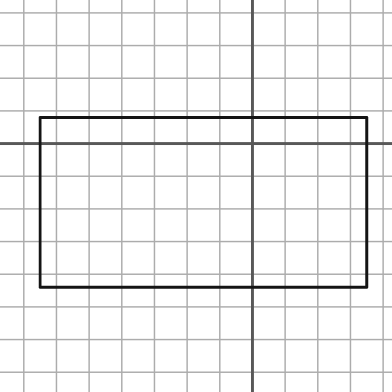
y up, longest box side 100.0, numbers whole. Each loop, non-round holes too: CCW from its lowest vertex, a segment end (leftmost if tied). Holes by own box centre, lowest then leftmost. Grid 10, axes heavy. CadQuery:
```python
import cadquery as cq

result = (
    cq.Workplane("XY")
    .moveTo(-65.0, -44.0)
    .lineTo(35.0, -44.0)
    .lineTo(35.0, 8.0)
    .lineTo(-65.0, 8.0)
    .close()
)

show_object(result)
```